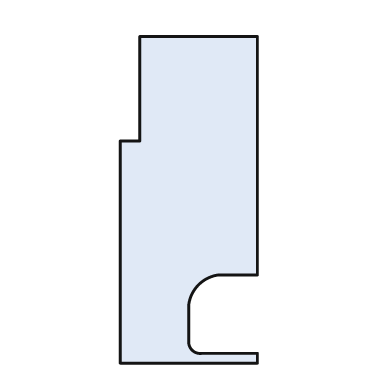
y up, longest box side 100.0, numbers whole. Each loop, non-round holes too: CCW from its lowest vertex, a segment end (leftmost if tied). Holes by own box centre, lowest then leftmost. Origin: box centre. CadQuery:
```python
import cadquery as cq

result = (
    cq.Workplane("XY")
    .moveTo(-21.0, -50.0)
    .lineTo(21.0, -50.0)
    .lineTo(21.0, -47.0)
    .lineTo(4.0, -47.0)
    .threePointArc((1.0, -46.0), (0.0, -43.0))
    .lineTo(0.0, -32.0)
    .threePointArc((3.0, -26.0), (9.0, -23.0))
    .lineTo(21.0, -23.0)
    .lineTo(21.0, 50.0)
    .lineTo(-15.0, 50.0)
    .lineTo(-15.0, 18.0)
    .lineTo(-21.0, 18.0)
    .close()
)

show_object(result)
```